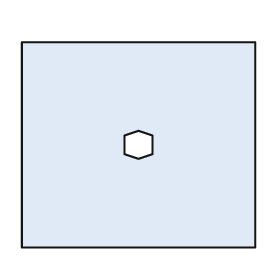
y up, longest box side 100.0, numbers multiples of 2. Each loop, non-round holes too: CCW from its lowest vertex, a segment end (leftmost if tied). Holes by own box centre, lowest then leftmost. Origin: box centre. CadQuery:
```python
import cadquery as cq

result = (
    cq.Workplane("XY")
    .moveTo(-50.0, -44.0)
    .lineTo(50.0, -44.0)
    .lineTo(50.0, 44.0)
    .lineTo(-50.0, 44.0)
    .close()
    .moveTo(0.0, -6.0)
    .lineTo(6.0, -4.0)
    .lineTo(6.0, 4.0)
    .lineTo(0.0, 6.0)
    .lineTo(-6.0, 4.0)
    .lineTo(-6.0, -4.0)
    .close()
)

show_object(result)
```